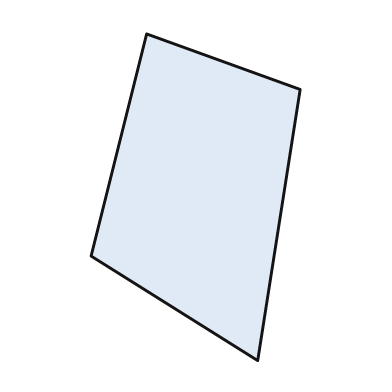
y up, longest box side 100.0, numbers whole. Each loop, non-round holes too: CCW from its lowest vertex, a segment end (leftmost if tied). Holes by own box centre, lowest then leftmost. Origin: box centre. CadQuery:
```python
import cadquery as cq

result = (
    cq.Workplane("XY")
    .moveTo(19.0, -50.0)
    .lineTo(32.0, 33.0)
    .lineTo(-15.0, 50.0)
    .lineTo(-32.0, -18.0)
    .close()
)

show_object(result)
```